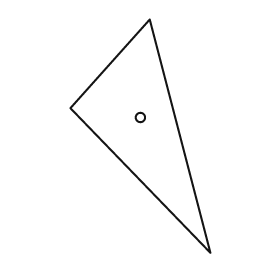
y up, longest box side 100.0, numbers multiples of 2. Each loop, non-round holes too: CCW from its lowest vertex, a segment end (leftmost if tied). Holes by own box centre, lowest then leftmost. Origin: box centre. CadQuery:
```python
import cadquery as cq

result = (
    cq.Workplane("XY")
    .moveTo(30.0, -50.0)
    .lineTo(4.0, 50.0)
    .lineTo(-30.0, 12.0)
    .close()
    .moveTo(0.0, 8.0)
    .circle(2.0)
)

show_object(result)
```